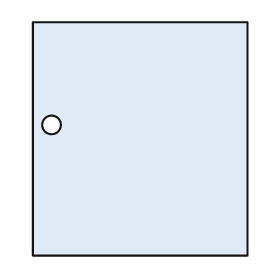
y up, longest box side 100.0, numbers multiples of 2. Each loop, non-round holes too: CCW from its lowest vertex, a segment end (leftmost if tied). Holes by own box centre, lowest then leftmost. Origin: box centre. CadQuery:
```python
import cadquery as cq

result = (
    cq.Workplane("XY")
    .moveTo(-46.0, -50.0)
    .lineTo(46.0, -50.0)
    .lineTo(46.0, 50.0)
    .lineTo(-46.0, 50.0)
    .close()
    .moveTo(-38.0, 6.0)
    .circle(4.0)
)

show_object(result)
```